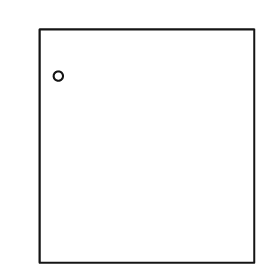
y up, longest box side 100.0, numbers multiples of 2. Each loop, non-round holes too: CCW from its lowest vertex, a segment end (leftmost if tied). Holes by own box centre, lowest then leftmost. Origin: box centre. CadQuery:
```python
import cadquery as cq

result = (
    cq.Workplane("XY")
    .moveTo(-46.0, -50.0)
    .lineTo(46.0, -50.0)
    .lineTo(46.0, 50.0)
    .lineTo(-46.0, 50.0)
    .close()
    .moveTo(-38.0, 30.0)
    .circle(2.0)
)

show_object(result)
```